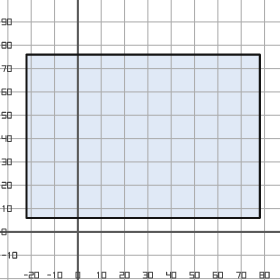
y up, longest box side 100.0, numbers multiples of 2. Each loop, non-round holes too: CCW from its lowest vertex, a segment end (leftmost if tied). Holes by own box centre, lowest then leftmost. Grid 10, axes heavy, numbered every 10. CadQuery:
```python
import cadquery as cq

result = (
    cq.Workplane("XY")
    .moveTo(-22.0, 6.0)
    .lineTo(78.0, 6.0)
    .lineTo(78.0, 76.0)
    .lineTo(-22.0, 76.0)
    .close()
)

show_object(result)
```